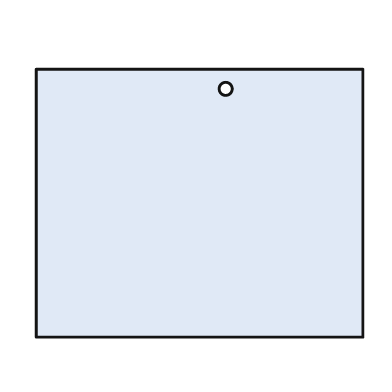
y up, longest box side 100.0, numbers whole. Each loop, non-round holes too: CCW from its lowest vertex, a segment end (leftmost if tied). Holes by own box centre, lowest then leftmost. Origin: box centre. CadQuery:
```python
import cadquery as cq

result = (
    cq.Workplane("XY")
    .moveTo(-50.0, -41.0)
    .lineTo(50.0, -41.0)
    .lineTo(50.0, 41.0)
    .lineTo(-50.0, 41.0)
    .close()
    .moveTo(8.0, 35.0)
    .circle(2.0)
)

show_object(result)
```